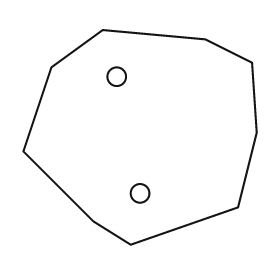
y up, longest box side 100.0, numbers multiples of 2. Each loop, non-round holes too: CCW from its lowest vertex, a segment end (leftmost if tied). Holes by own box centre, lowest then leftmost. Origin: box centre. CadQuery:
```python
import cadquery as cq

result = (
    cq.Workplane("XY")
    .moveTo(-4.0, -46.0)
    .lineTo(42.0, -30.0)
    .lineTo(50.0, 2.0)
    .lineTo(48.0, 32.0)
    .lineTo(28.0, 42.0)
    .lineTo(-16.0, 46.0)
    .lineTo(-38.0, 30.0)
    .lineTo(-50.0, -6.0)
    .lineTo(-20.0, -36.0)
    .close()
    .moveTo(0.0, -24.0)
    .circle(4.0)
    .moveTo(-10.0, 26.0)
    .circle(4.0)
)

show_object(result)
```